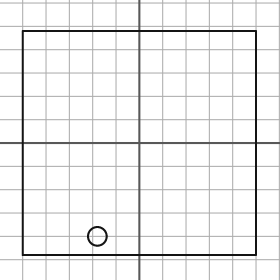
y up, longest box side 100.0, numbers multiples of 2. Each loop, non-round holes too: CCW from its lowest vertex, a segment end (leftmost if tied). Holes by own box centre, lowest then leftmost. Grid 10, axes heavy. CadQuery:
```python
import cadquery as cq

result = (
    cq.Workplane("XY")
    .moveTo(-50.0, -48.0)
    .lineTo(50.0, -48.0)
    .lineTo(50.0, 48.0)
    .lineTo(-50.0, 48.0)
    .close()
    .moveTo(-18.0, -40.0)
    .circle(4.0)
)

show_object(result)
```